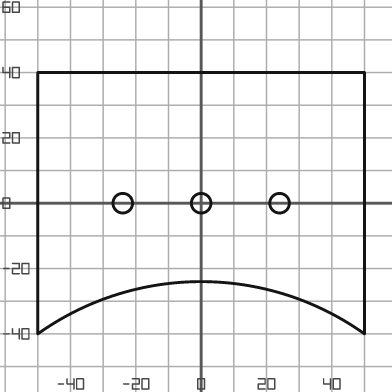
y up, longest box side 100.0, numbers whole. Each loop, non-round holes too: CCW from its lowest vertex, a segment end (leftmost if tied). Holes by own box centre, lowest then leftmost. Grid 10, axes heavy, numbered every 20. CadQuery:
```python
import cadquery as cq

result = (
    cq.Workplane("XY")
    .moveTo(-50.0, -40.0)
    .threePointArc((0.0, -24.0), (50.0, -40.0))
    .lineTo(50.0, 40.0)
    .lineTo(-50.0, 40.0)
    .close()
    .moveTo(-24.0, 0.0)
    .circle(3.0)
    .moveTo(0.0, 0.0)
    .circle(3.0)
    .moveTo(24.0, 0.0)
    .circle(3.0)
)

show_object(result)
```